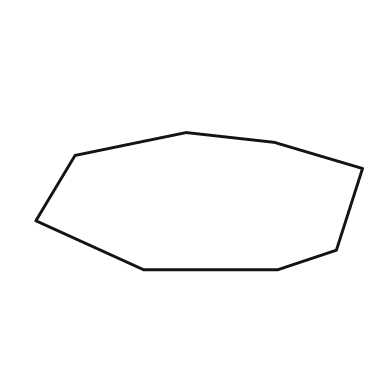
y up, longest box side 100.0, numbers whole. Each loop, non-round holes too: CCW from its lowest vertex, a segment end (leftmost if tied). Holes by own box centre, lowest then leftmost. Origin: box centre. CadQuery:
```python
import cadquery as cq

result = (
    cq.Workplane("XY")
    .moveTo(-17.0, -21.0)
    .lineTo(24.0, -21.0)
    .lineTo(42.0, -15.0)
    .lineTo(50.0, 10.0)
    .lineTo(23.0, 18.0)
    .lineTo(-4.0, 21.0)
    .lineTo(-38.0, 14.0)
    .lineTo(-50.0, -6.0)
    .close()
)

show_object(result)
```